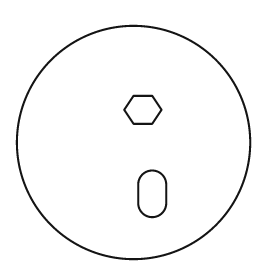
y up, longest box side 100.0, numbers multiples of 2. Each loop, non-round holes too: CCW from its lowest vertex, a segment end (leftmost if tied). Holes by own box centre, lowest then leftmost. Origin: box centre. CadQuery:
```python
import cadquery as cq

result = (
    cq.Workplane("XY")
    .moveTo(0.0, 0.0)
    .circle(50.0)
    .moveTo(2.0, -26.0)
    .threePointArc((8.0, -32.0), (14.0, -26.0))
    .lineTo(14.0, -18.0)
    .threePointArc((8.0, -12.0), (2.0, -18.0))
    .close()
    .moveTo(0.0, 8.0)
    .lineTo(8.0, 8.0)
    .lineTo(12.0, 14.0)
    .lineTo(8.0, 20.0)
    .lineTo(0.0, 20.0)
    .lineTo(-4.0, 14.0)
    .close()
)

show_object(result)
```